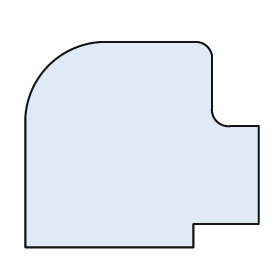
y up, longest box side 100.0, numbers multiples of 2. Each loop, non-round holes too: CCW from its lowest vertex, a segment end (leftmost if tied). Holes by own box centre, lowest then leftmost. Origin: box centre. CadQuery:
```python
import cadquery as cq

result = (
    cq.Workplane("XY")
    .moveTo(-50.0, -44.0)
    .lineTo(22.0, -44.0)
    .lineTo(22.0, -34.0)
    .lineTo(50.0, -34.0)
    .lineTo(50.0, 8.0)
    .lineTo(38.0, 8.0)
    .threePointArc((32.0, 10.0), (30.0, 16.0))
    .lineTo(30.0, 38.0)
    .threePointArc((28.0, 42.0), (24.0, 44.0))
    .lineTo(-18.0, 44.0)
    .threePointArc((-40.0, 34.0), (-50.0, 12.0))
    .close()
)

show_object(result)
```